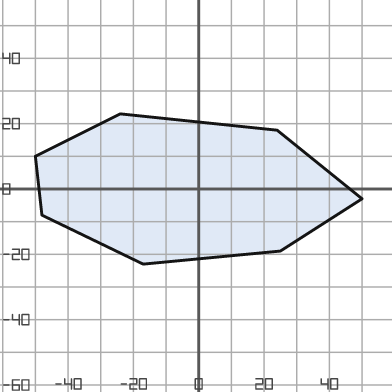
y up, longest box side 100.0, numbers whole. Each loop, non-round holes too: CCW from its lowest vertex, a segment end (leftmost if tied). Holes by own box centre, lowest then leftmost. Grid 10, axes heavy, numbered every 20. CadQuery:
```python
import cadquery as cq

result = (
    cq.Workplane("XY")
    .moveTo(-17.0, -23.0)
    .lineTo(25.0, -19.0)
    .lineTo(50.0, -3.0)
    .lineTo(24.0, 18.0)
    .lineTo(-24.0, 23.0)
    .lineTo(-50.0, 10.0)
    .lineTo(-48.0, -8.0)
    .close()
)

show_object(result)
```